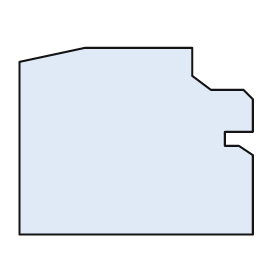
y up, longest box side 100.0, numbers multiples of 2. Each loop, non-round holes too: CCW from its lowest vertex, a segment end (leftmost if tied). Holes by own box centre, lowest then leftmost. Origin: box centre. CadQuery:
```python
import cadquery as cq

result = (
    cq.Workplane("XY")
    .moveTo(-50.0, -40.0)
    .lineTo(50.0, -40.0)
    .lineTo(50.0, -6.0)
    .lineTo(44.0, -2.0)
    .lineTo(38.0, -2.0)
    .lineTo(38.0, 4.0)
    .lineTo(50.0, 4.0)
    .lineTo(50.0, 18.0)
    .lineTo(46.0, 22.0)
    .lineTo(32.0, 22.0)
    .lineTo(24.0, 28.0)
    .lineTo(24.0, 40.0)
    .lineTo(-22.0, 40.0)
    .lineTo(-50.0, 34.0)
    .close()
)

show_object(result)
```